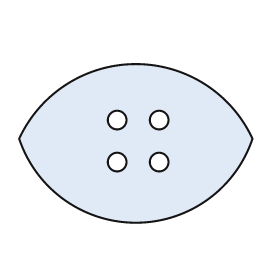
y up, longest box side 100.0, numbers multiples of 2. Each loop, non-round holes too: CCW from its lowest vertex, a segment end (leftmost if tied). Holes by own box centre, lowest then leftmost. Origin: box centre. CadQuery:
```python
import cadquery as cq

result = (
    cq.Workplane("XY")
    .moveTo(-50.0, 2.0)
    .threePointArc((0.0, -34.0), (50.0, 2.0))
    .threePointArc((0.0, 34.0), (-50.0, 2.0))
    .close()
    .moveTo(-8.0, -8.0)
    .circle(4.0)
    .moveTo(10.0, -8.0)
    .circle(4.0)
    .moveTo(-8.0, 10.0)
    .circle(4.0)
    .moveTo(10.0, 10.0)
    .circle(4.0)
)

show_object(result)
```